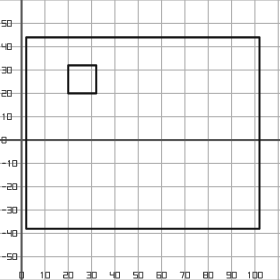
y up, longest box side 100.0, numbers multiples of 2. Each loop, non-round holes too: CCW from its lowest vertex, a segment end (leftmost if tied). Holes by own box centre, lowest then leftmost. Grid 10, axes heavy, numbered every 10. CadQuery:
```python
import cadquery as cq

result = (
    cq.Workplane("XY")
    .moveTo(2.0, -38.0)
    .lineTo(102.0, -38.0)
    .lineTo(102.0, 44.0)
    .lineTo(2.0, 44.0)
    .close()
    .moveTo(20.0, 20.0)
    .lineTo(32.0, 20.0)
    .lineTo(32.0, 32.0)
    .lineTo(20.0, 32.0)
    .close()
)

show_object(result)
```